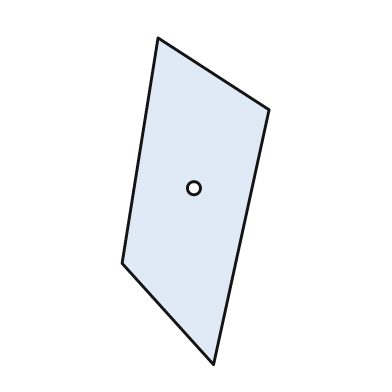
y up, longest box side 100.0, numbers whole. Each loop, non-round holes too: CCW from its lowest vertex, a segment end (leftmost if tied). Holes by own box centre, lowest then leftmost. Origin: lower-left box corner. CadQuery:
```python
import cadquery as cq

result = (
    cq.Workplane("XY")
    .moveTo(28.0, 0.0)
    .lineTo(45.0, 78.0)
    .lineTo(11.0, 100.0)
    .lineTo(0.0, 31.0)
    .close()
    .moveTo(22.0, 54.0)
    .circle(2.0)
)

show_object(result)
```